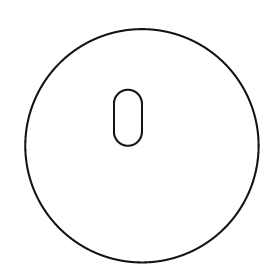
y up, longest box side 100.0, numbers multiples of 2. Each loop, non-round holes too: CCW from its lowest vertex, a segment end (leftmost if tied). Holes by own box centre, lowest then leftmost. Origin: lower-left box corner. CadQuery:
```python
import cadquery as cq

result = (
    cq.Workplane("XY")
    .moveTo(50.0, 50.0)
    .circle(50.0)
    .moveTo(38.0, 56.0)
    .threePointArc((44.0, 50.0), (50.0, 56.0))
    .lineTo(50.0, 68.0)
    .threePointArc((44.0, 74.0), (38.0, 68.0))
    .close()
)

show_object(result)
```